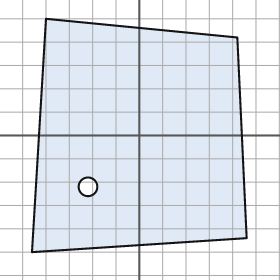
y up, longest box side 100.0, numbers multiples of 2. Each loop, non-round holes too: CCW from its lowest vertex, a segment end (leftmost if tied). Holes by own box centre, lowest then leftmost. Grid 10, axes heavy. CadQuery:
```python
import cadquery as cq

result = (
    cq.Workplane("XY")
    .moveTo(-46.0, -50.0)
    .lineTo(46.0, -44.0)
    .lineTo(42.0, 42.0)
    .lineTo(-40.0, 50.0)
    .close()
    .moveTo(-22.0, -22.0)
    .circle(4.0)
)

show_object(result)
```